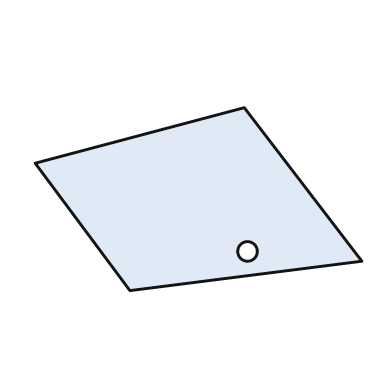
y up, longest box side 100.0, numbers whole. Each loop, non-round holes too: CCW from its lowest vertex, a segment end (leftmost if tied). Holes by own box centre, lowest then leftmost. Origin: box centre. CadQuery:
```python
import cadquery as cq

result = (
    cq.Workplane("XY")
    .moveTo(-21.0, -28.0)
    .lineTo(50.0, -19.0)
    .lineTo(14.0, 28.0)
    .lineTo(-50.0, 11.0)
    .close()
    .moveTo(15.0, -16.0)
    .circle(3.0)
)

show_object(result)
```